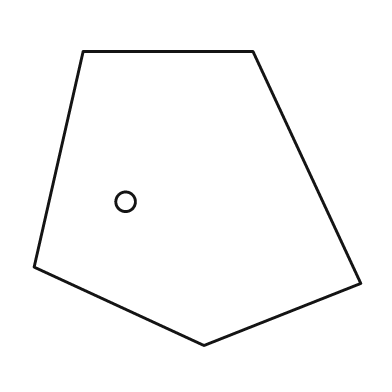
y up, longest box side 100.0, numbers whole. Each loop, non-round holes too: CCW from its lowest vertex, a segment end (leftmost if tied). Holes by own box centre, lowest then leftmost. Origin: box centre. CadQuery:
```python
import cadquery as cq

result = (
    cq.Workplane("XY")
    .moveTo(2.0, -45.0)
    .lineTo(50.0, -26.0)
    .lineTo(17.0, 45.0)
    .lineTo(-35.0, 45.0)
    .lineTo(-50.0, -21.0)
    .close()
    .moveTo(-22.0, -1.0)
    .circle(3.0)
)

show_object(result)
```